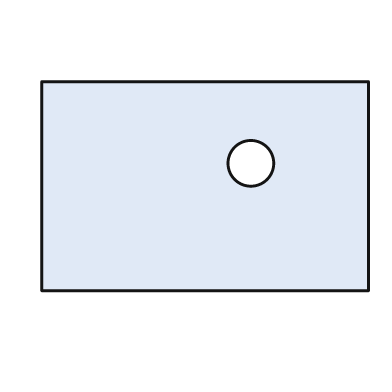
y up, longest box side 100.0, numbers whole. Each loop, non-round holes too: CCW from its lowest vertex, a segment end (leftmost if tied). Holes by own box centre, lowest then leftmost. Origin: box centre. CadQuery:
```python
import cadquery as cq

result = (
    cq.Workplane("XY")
    .moveTo(-50.0, -32.0)
    .lineTo(50.0, -32.0)
    .lineTo(50.0, 32.0)
    .lineTo(-50.0, 32.0)
    .close()
    .moveTo(14.0, 7.0)
    .circle(7.0)
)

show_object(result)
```